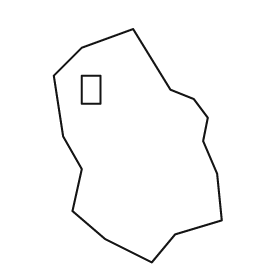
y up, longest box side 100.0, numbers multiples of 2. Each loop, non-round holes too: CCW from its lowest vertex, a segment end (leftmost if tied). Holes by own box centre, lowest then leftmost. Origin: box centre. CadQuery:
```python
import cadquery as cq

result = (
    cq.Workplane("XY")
    .moveTo(6.0, -50.0)
    .lineTo(16.0, -38.0)
    .lineTo(36.0, -32.0)
    .lineTo(34.0, -12.0)
    .lineTo(28.0, 2.0)
    .lineTo(30.0, 12.0)
    .lineTo(24.0, 20.0)
    .lineTo(14.0, 24.0)
    .lineTo(-2.0, 50.0)
    .lineTo(-24.0, 42.0)
    .lineTo(-36.0, 30.0)
    .lineTo(-32.0, 4.0)
    .lineTo(-24.0, -10.0)
    .lineTo(-28.0, -28.0)
    .lineTo(-14.0, -40.0)
    .close()
    .moveTo(-24.0, 18.0)
    .lineTo(-16.0, 18.0)
    .lineTo(-16.0, 30.0)
    .lineTo(-24.0, 30.0)
    .close()
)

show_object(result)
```